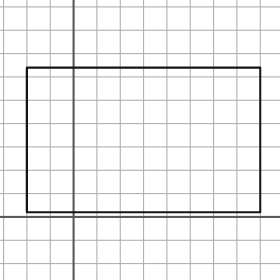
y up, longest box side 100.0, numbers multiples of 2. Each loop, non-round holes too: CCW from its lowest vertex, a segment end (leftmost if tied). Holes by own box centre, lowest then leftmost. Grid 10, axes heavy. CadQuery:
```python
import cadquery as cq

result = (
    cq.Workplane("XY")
    .moveTo(-20.0, 2.0)
    .lineTo(80.0, 2.0)
    .lineTo(80.0, 64.0)
    .lineTo(-20.0, 64.0)
    .close()
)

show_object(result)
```